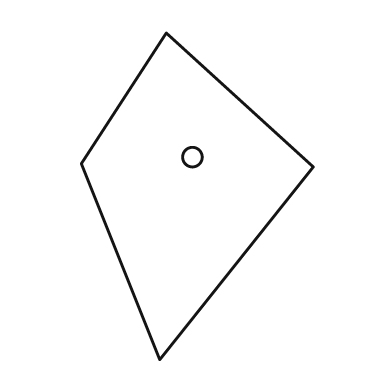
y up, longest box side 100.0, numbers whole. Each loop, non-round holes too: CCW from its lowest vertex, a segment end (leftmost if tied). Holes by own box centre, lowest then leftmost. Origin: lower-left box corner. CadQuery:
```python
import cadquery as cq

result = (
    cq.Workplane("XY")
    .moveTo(24.0, 0.0)
    .lineTo(71.0, 59.0)
    .lineTo(26.0, 100.0)
    .lineTo(0.0, 60.0)
    .close()
    .moveTo(34.0, 62.0)
    .circle(3.0)
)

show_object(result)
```